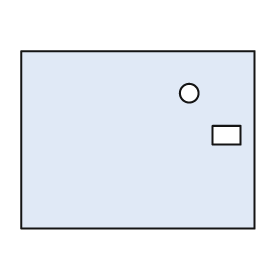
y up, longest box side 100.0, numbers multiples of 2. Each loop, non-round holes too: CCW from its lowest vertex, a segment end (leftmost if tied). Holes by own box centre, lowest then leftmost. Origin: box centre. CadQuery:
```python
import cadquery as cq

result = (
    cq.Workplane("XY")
    .moveTo(-50.0, -38.0)
    .lineTo(50.0, -38.0)
    .lineTo(50.0, 38.0)
    .lineTo(-50.0, 38.0)
    .close()
    .moveTo(32.0, -2.0)
    .lineTo(44.0, -2.0)
    .lineTo(44.0, 6.0)
    .lineTo(32.0, 6.0)
    .close()
    .moveTo(22.0, 20.0)
    .circle(4.0)
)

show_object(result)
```